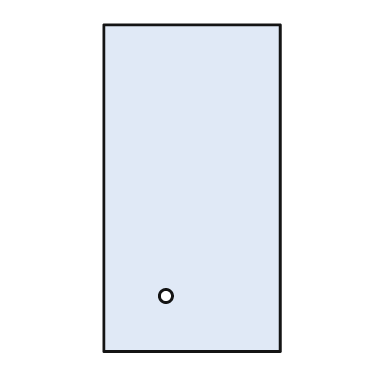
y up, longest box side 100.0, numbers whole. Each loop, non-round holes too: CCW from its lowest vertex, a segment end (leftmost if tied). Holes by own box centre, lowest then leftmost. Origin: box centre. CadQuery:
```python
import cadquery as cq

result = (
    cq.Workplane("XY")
    .moveTo(-27.0, -50.0)
    .lineTo(27.0, -50.0)
    .lineTo(27.0, 50.0)
    .lineTo(-27.0, 50.0)
    .close()
    .moveTo(-8.0, -33.0)
    .circle(2.0)
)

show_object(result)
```